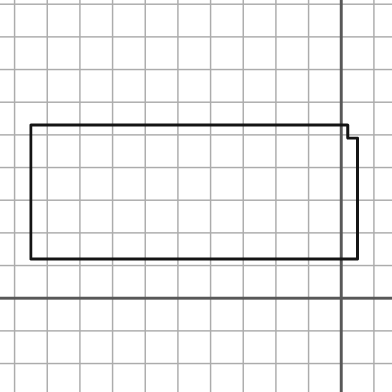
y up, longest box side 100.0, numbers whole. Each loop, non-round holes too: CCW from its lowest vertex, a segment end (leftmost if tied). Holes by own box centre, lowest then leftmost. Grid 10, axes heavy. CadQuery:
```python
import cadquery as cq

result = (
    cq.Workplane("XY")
    .moveTo(-95.0, 12.0)
    .lineTo(5.0, 12.0)
    .lineTo(5.0, 49.0)
    .lineTo(2.0, 49.0)
    .lineTo(2.0, 53.0)
    .lineTo(-95.0, 53.0)
    .close()
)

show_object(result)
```